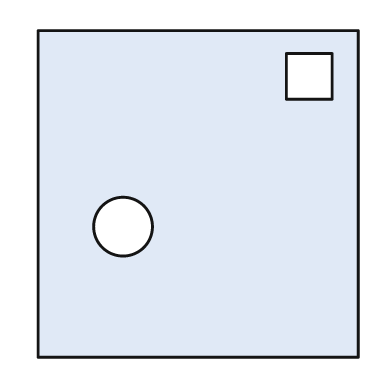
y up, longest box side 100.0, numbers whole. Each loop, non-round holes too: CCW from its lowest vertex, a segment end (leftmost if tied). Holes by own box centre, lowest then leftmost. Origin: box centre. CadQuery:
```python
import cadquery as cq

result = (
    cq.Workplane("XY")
    .moveTo(-49.0, -50.0)
    .lineTo(49.0, -50.0)
    .lineTo(49.0, 50.0)
    .lineTo(-49.0, 50.0)
    .close()
    .moveTo(-23.0, -10.0)
    .circle(9.0)
    .moveTo(27.0, 29.0)
    .lineTo(41.0, 29.0)
    .lineTo(41.0, 43.0)
    .lineTo(27.0, 43.0)
    .close()
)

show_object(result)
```